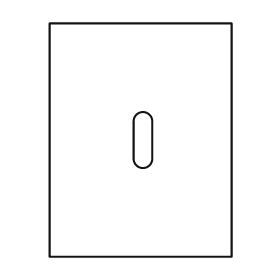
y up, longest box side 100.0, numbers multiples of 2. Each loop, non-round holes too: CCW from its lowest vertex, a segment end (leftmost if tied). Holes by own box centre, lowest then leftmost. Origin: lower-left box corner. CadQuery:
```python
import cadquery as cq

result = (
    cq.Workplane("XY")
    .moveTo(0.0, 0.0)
    .lineTo(78.0, 0.0)
    .lineTo(78.0, 100.0)
    .lineTo(0.0, 100.0)
    .close()
    .moveTo(36.0, 42.0)
    .threePointArc((40.0, 38.0), (44.0, 42.0))
    .lineTo(44.0, 58.0)
    .threePointArc((40.0, 62.0), (36.0, 58.0))
    .close()
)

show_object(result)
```